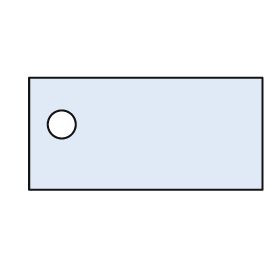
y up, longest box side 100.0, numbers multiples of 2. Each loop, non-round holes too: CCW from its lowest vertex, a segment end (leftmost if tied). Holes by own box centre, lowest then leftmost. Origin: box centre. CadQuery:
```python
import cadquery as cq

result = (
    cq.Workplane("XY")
    .moveTo(-50.0, -24.0)
    .lineTo(50.0, -24.0)
    .lineTo(50.0, 24.0)
    .lineTo(-50.0, 24.0)
    .close()
    .moveTo(-36.0, 4.0)
    .circle(6.0)
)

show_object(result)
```